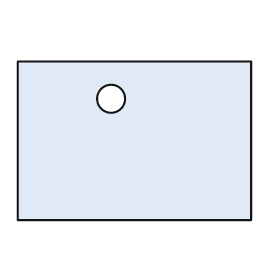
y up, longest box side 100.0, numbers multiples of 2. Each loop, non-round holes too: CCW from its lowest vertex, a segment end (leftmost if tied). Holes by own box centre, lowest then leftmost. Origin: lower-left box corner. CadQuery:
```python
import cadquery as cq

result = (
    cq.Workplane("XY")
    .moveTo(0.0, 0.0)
    .lineTo(100.0, 0.0)
    .lineTo(100.0, 68.0)
    .lineTo(0.0, 68.0)
    .close()
    .moveTo(40.0, 52.0)
    .circle(6.0)
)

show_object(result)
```